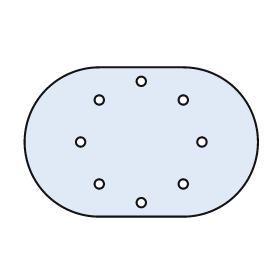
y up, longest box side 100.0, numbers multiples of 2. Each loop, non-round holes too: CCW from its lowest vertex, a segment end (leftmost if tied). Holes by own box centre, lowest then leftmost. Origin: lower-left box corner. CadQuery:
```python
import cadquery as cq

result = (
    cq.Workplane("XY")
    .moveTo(32.0, 0.0)
    .lineTo(68.0, 0.0)
    .threePointArc((100.0, 32.0), (68.0, 64.0))
    .lineTo(32.0, 64.0)
    .threePointArc((0.0, 32.0), (32.0, 0.0))
    .close()
    .moveTo(50.0, 6.0)
    .circle(2.0)
    .moveTo(32.0, 14.0)
    .circle(2.0)
    .moveTo(68.0, 14.0)
    .circle(2.0)
    .moveTo(24.0, 32.0)
    .circle(2.0)
    .moveTo(76.0, 32.0)
    .circle(2.0)
    .moveTo(32.0, 50.0)
    .circle(2.0)
    .moveTo(68.0, 50.0)
    .circle(2.0)
    .moveTo(50.0, 58.0)
    .circle(2.0)
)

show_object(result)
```